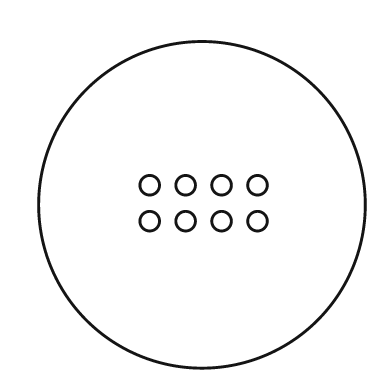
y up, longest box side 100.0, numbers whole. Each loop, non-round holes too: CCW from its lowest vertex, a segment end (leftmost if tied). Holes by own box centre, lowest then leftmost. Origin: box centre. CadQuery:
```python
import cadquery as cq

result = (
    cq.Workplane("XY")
    .moveTo(0.0, 0.0)
    .circle(50.0)
    .moveTo(-16.0, -5.0)
    .circle(3.0)
    .moveTo(-5.0, -5.0)
    .circle(3.0)
    .moveTo(6.0, -5.0)
    .circle(3.0)
    .moveTo(17.0, -5.0)
    .circle(3.0)
    .moveTo(-16.0, 6.0)
    .circle(3.0)
    .moveTo(-5.0, 6.0)
    .circle(3.0)
    .moveTo(6.0, 6.0)
    .circle(3.0)
    .moveTo(17.0, 6.0)
    .circle(3.0)
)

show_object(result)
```